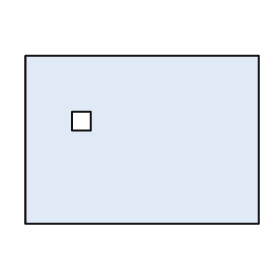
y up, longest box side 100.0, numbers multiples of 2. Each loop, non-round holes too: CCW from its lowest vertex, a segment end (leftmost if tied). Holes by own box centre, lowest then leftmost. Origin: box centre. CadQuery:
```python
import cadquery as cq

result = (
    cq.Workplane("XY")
    .moveTo(-50.0, -36.0)
    .lineTo(50.0, -36.0)
    .lineTo(50.0, 36.0)
    .lineTo(-50.0, 36.0)
    .close()
    .moveTo(-30.0, 4.0)
    .lineTo(-22.0, 4.0)
    .lineTo(-22.0, 12.0)
    .lineTo(-30.0, 12.0)
    .close()
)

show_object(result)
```